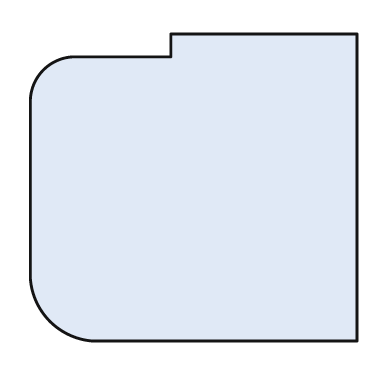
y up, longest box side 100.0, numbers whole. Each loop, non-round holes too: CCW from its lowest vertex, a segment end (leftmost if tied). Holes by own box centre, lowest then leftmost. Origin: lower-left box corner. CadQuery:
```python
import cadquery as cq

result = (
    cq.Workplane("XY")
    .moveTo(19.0, 0.0)
    .lineTo(100.0, 0.0)
    .lineTo(100.0, 94.0)
    .lineTo(43.0, 94.0)
    .lineTo(43.0, 87.0)
    .lineTo(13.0, 87.0)
    .threePointArc((4.0, 83.0), (0.0, 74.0))
    .lineTo(0.0, 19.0)
    .threePointArc((6.0, 6.0), (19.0, 0.0))
    .close()
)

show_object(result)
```